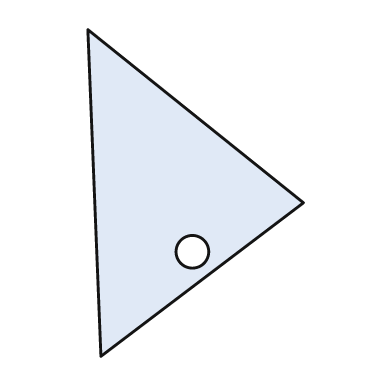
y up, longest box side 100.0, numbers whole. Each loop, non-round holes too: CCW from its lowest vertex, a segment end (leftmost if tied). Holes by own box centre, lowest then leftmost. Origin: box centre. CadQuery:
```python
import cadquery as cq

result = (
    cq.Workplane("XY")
    .moveTo(-29.0, -50.0)
    .lineTo(33.0, -3.0)
    .lineTo(-33.0, 50.0)
    .close()
    .moveTo(-1.0, -18.0)
    .circle(5.0)
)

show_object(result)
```